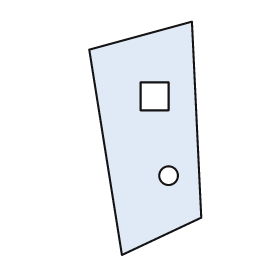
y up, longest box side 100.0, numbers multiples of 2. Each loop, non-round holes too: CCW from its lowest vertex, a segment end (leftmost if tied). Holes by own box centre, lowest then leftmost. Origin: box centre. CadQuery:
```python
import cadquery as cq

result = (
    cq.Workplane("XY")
    .moveTo(-10.0, -50.0)
    .lineTo(24.0, -34.0)
    .lineTo(20.0, 50.0)
    .lineTo(-24.0, 38.0)
    .close()
    .moveTo(10.0, -16.0)
    .circle(4.0)
    .moveTo(-2.0, 12.0)
    .lineTo(10.0, 12.0)
    .lineTo(10.0, 24.0)
    .lineTo(-2.0, 24.0)
    .close()
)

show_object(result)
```